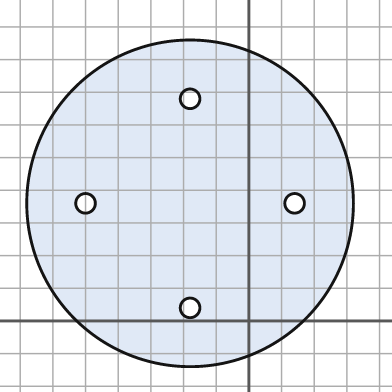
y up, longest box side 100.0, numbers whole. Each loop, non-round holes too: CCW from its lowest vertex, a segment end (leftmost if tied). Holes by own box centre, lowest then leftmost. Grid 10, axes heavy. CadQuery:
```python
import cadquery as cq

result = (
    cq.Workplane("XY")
    .moveTo(-18.0, 36.0)
    .circle(50.0)
    .moveTo(-18.0, 4.0)
    .circle(3.0)
    .moveTo(-50.0, 36.0)
    .circle(3.0)
    .moveTo(14.0, 36.0)
    .circle(3.0)
    .moveTo(-18.0, 68.0)
    .circle(3.0)
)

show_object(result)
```